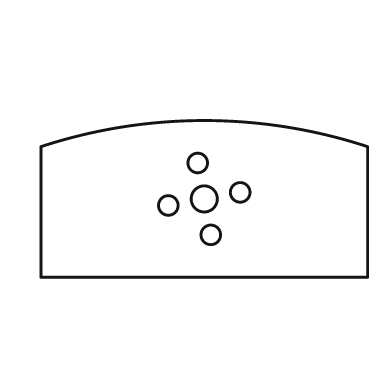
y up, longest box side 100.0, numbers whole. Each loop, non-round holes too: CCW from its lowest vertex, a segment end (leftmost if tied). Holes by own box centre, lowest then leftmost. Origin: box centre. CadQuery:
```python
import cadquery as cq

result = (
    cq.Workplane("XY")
    .moveTo(-50.0, -24.0)
    .lineTo(50.0, -24.0)
    .lineTo(50.0, 16.0)
    .threePointArc((0.0, 24.0), (-50.0, 16.0))
    .close()
    .moveTo(2.0, -11.0)
    .circle(3.0)
    .moveTo(-11.0, -2.0)
    .circle(3.0)
    .moveTo(0.0, 0.0)
    .circle(4.0)
    .moveTo(11.0, 2.0)
    .circle(3.0)
    .moveTo(-2.0, 11.0)
    .circle(3.0)
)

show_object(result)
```